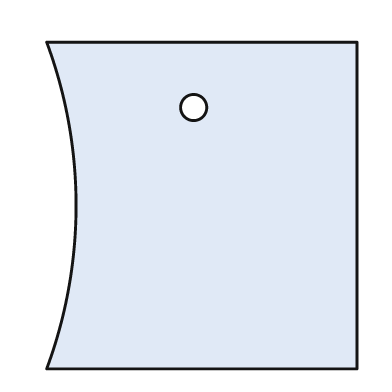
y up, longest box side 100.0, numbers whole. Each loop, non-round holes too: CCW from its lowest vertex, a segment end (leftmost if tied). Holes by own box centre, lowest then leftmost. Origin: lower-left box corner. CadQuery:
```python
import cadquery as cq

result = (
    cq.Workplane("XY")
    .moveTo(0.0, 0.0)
    .lineTo(95.0, 0.0)
    .lineTo(95.0, 100.0)
    .lineTo(0.0, 100.0)
    .threePointArc((9.0, 50.0), (0.0, 0.0))
    .close()
    .moveTo(45.0, 80.0)
    .circle(4.0)
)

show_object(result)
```